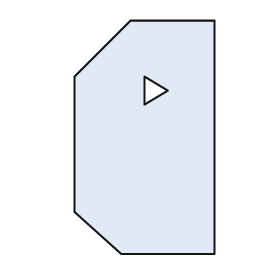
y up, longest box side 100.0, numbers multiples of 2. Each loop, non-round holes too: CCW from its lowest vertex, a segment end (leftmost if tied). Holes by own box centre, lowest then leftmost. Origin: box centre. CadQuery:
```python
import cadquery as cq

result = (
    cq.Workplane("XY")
    .moveTo(-10.0, -50.0)
    .lineTo(30.0, -50.0)
    .lineTo(30.0, 50.0)
    .lineTo(-6.0, 50.0)
    .lineTo(-30.0, 26.0)
    .lineTo(-30.0, -32.0)
    .close()
    .moveTo(0.0, 14.0)
    .lineTo(10.0, 20.0)
    .lineTo(0.0, 26.0)
    .close()
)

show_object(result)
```